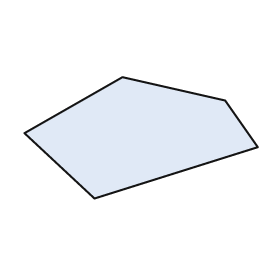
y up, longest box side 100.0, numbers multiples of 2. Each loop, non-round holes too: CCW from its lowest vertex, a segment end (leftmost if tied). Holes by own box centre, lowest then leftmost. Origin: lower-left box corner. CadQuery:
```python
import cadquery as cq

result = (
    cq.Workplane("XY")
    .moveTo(30.0, 0.0)
    .lineTo(100.0, 22.0)
    .lineTo(86.0, 42.0)
    .lineTo(42.0, 52.0)
    .lineTo(0.0, 28.0)
    .close()
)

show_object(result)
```